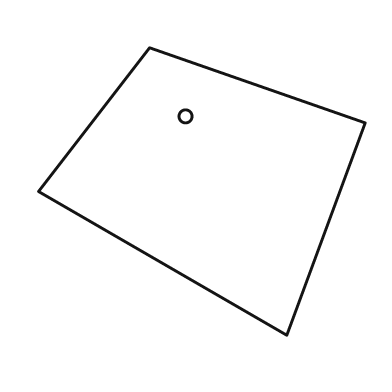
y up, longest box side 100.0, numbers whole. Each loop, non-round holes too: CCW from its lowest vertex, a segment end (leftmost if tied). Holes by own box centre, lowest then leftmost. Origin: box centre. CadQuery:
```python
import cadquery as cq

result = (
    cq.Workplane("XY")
    .moveTo(26.0, -44.0)
    .lineTo(50.0, 21.0)
    .lineTo(-16.0, 44.0)
    .lineTo(-50.0, 0.0)
    .close()
    .moveTo(-5.0, 23.0)
    .circle(2.0)
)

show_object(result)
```